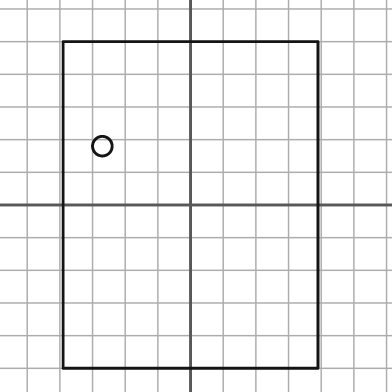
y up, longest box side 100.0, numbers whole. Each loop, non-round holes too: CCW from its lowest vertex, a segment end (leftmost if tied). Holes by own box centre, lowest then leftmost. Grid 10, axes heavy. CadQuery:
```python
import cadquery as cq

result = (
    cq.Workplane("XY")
    .moveTo(-39.0, -50.0)
    .lineTo(39.0, -50.0)
    .lineTo(39.0, 50.0)
    .lineTo(-39.0, 50.0)
    .close()
    .moveTo(-27.0, 18.0)
    .circle(3.0)
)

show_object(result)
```